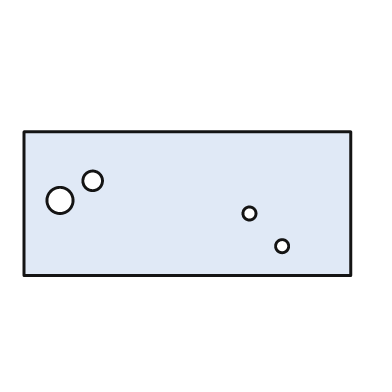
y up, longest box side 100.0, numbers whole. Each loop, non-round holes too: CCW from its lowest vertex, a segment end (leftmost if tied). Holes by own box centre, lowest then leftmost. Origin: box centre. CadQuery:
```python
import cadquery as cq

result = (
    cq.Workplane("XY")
    .moveTo(-50.0, -22.0)
    .lineTo(50.0, -22.0)
    .lineTo(50.0, 22.0)
    .lineTo(-50.0, 22.0)
    .close()
    .moveTo(29.0, -13.0)
    .circle(2.0)
    .moveTo(19.0, -3.0)
    .circle(2.0)
    .moveTo(-39.0, 1.0)
    .circle(4.0)
    .moveTo(-29.0, 7.0)
    .circle(3.0)
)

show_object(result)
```